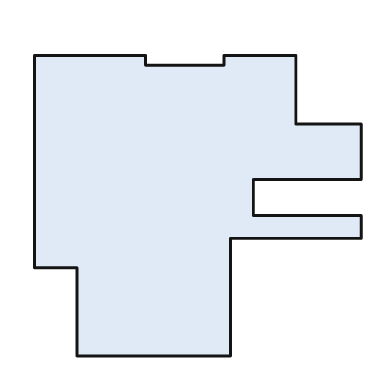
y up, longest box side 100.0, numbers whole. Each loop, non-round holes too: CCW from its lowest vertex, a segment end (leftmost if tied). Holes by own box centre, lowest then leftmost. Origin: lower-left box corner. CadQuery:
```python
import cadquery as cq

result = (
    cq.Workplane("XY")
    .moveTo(13.0, 0.0)
    .lineTo(60.0, 0.0)
    .lineTo(60.0, 36.0)
    .lineTo(100.0, 36.0)
    .lineTo(100.0, 43.0)
    .lineTo(67.0, 43.0)
    .lineTo(67.0, 54.0)
    .lineTo(100.0, 54.0)
    .lineTo(100.0, 71.0)
    .lineTo(80.0, 71.0)
    .lineTo(80.0, 92.0)
    .lineTo(58.0, 92.0)
    .lineTo(58.0, 89.0)
    .lineTo(34.0, 89.0)
    .lineTo(34.0, 92.0)
    .lineTo(0.0, 92.0)
    .lineTo(0.0, 27.0)
    .lineTo(13.0, 27.0)
    .close()
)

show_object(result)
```